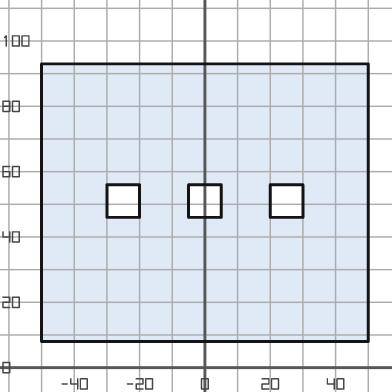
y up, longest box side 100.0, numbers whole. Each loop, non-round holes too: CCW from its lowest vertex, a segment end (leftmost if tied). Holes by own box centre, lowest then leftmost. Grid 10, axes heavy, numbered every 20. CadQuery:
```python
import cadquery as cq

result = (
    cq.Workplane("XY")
    .moveTo(-50.0, 8.0)
    .lineTo(50.0, 8.0)
    .lineTo(50.0, 93.0)
    .lineTo(-50.0, 93.0)
    .close()
    .moveTo(-30.0, 46.0)
    .lineTo(-20.0, 46.0)
    .lineTo(-20.0, 56.0)
    .lineTo(-30.0, 56.0)
    .close()
    .moveTo(-5.0, 46.0)
    .lineTo(5.0, 46.0)
    .lineTo(5.0, 56.0)
    .lineTo(-5.0, 56.0)
    .close()
    .moveTo(20.0, 46.0)
    .lineTo(30.0, 46.0)
    .lineTo(30.0, 56.0)
    .lineTo(20.0, 56.0)
    .close()
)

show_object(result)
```